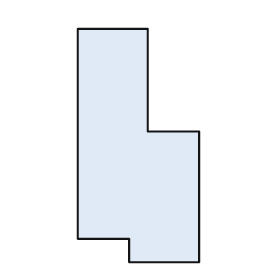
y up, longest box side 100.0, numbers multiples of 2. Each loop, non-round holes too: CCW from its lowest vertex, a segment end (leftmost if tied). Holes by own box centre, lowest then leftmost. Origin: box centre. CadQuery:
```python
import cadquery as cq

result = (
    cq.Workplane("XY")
    .moveTo(-4.0, -50.0)
    .lineTo(26.0, -50.0)
    .lineTo(26.0, 6.0)
    .lineTo(4.0, 6.0)
    .lineTo(4.0, 50.0)
    .lineTo(-26.0, 50.0)
    .lineTo(-26.0, -40.0)
    .lineTo(-4.0, -40.0)
    .close()
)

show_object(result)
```